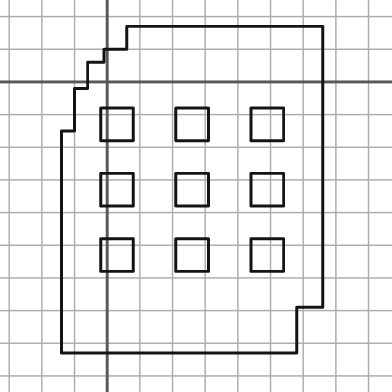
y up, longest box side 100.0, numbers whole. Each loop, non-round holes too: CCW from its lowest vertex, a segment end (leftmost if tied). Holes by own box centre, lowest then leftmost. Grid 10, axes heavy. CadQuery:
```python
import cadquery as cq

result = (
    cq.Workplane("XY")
    .moveTo(-14.0, -83.0)
    .lineTo(58.0, -83.0)
    .lineTo(58.0, -69.0)
    .lineTo(66.0, -69.0)
    .lineTo(66.0, 17.0)
    .lineTo(6.0, 17.0)
    .lineTo(6.0, 10.0)
    .lineTo(-1.0, 10.0)
    .lineTo(-1.0, 6.0)
    .lineTo(-6.0, 6.0)
    .lineTo(-6.0, -2.0)
    .lineTo(-10.0, -2.0)
    .lineTo(-10.0, -15.0)
    .lineTo(-14.0, -15.0)
    .close()
    .moveTo(-2.0, -58.0)
    .lineTo(8.0, -58.0)
    .lineTo(8.0, -48.0)
    .lineTo(-2.0, -48.0)
    .close()
    .moveTo(21.0, -58.0)
    .lineTo(31.0, -58.0)
    .lineTo(31.0, -48.0)
    .lineTo(21.0, -48.0)
    .close()
    .moveTo(44.0, -58.0)
    .lineTo(54.0, -58.0)
    .lineTo(54.0, -48.0)
    .lineTo(44.0, -48.0)
    .close()
    .moveTo(-2.0, -38.0)
    .lineTo(8.0, -38.0)
    .lineTo(8.0, -28.0)
    .lineTo(-2.0, -28.0)
    .close()
    .moveTo(21.0, -38.0)
    .lineTo(31.0, -38.0)
    .lineTo(31.0, -28.0)
    .lineTo(21.0, -28.0)
    .close()
    .moveTo(44.0, -38.0)
    .lineTo(54.0, -38.0)
    .lineTo(54.0, -28.0)
    .lineTo(44.0, -28.0)
    .close()
    .moveTo(-2.0, -18.0)
    .lineTo(8.0, -18.0)
    .lineTo(8.0, -8.0)
    .lineTo(-2.0, -8.0)
    .close()
    .moveTo(21.0, -18.0)
    .lineTo(31.0, -18.0)
    .lineTo(31.0, -8.0)
    .lineTo(21.0, -8.0)
    .close()
    .moveTo(44.0, -18.0)
    .lineTo(54.0, -18.0)
    .lineTo(54.0, -8.0)
    .lineTo(44.0, -8.0)
    .close()
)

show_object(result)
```